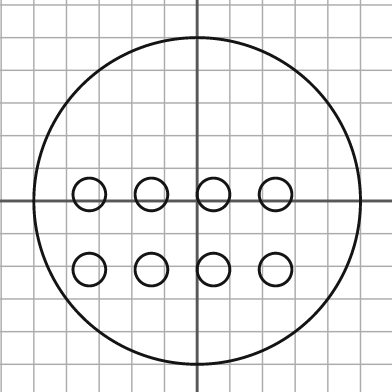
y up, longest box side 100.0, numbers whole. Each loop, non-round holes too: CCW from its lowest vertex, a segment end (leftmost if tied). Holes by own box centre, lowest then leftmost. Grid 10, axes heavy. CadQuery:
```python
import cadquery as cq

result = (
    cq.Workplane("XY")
    .moveTo(0.0, 0.0)
    .circle(50.0)
    .moveTo(-33.0, -21.0)
    .circle(5.0)
    .moveTo(-14.0, -21.0)
    .circle(5.0)
    .moveTo(5.0, -21.0)
    .circle(5.0)
    .moveTo(24.0, -21.0)
    .circle(5.0)
    .moveTo(-33.0, 2.0)
    .circle(5.0)
    .moveTo(-14.0, 2.0)
    .circle(5.0)
    .moveTo(5.0, 2.0)
    .circle(5.0)
    .moveTo(24.0, 2.0)
    .circle(5.0)
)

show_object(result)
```